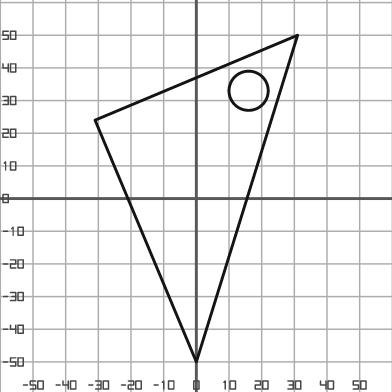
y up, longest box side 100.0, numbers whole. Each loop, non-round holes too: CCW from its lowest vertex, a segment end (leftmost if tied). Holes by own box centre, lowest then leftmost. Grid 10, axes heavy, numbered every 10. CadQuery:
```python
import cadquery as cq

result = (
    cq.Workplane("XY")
    .moveTo(0.0, -50.0)
    .lineTo(31.0, 50.0)
    .lineTo(-31.0, 24.0)
    .close()
    .moveTo(16.0, 33.0)
    .circle(6.0)
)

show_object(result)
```